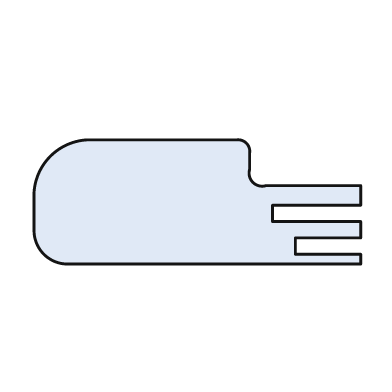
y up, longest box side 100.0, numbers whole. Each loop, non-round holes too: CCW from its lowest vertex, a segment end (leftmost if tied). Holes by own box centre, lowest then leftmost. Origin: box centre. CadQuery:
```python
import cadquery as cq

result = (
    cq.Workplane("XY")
    .moveTo(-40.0, -19.0)
    .lineTo(50.0, -19.0)
    .lineTo(50.0, -16.0)
    .lineTo(30.0, -16.0)
    .lineTo(30.0, -11.0)
    .lineTo(50.0, -11.0)
    .lineTo(50.0, -6.0)
    .lineTo(23.0, -6.0)
    .lineTo(23.0, -1.0)
    .lineTo(50.0, -1.0)
    .lineTo(50.0, 5.0)
    .lineTo(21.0, 5.0)
    .threePointArc((17.0, 6.0), (16.0, 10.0))
    .lineTo(16.0, 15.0)
    .threePointArc((15.0, 18.0), (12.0, 19.0))
    .lineTo(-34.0, 19.0)
    .threePointArc((-45.0, 14.0), (-50.0, 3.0))
    .lineTo(-50.0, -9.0)
    .threePointArc((-47.0, -16.0), (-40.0, -19.0))
    .close()
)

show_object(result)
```